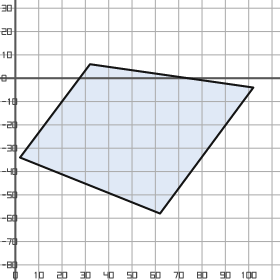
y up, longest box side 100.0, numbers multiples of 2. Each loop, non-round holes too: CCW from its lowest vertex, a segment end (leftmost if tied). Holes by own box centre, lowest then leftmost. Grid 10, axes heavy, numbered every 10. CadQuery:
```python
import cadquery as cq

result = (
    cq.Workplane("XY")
    .moveTo(62.0, -58.0)
    .lineTo(102.0, -4.0)
    .lineTo(32.0, 6.0)
    .lineTo(2.0, -34.0)
    .close()
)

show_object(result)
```